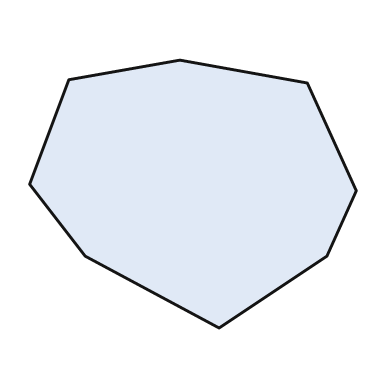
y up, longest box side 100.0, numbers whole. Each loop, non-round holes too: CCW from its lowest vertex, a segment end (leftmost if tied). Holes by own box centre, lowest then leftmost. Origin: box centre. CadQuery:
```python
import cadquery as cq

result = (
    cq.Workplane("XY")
    .moveTo(8.0, -41.0)
    .lineTo(41.0, -19.0)
    .lineTo(50.0, 1.0)
    .lineTo(35.0, 34.0)
    .lineTo(-4.0, 41.0)
    .lineTo(-38.0, 35.0)
    .lineTo(-50.0, 3.0)
    .lineTo(-33.0, -19.0)
    .close()
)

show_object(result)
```